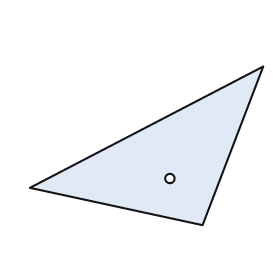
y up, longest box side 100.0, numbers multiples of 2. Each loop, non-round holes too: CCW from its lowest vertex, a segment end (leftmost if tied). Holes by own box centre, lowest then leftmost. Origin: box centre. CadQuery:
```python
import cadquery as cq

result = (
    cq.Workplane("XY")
    .moveTo(24.0, -34.0)
    .lineTo(50.0, 34.0)
    .lineTo(-50.0, -18.0)
    .close()
    .moveTo(10.0, -14.0)
    .circle(2.0)
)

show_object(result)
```